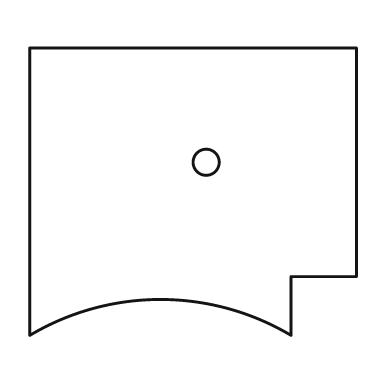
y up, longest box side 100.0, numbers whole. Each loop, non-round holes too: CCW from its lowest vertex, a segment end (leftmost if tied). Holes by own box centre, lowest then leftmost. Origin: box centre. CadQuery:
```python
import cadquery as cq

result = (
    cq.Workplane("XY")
    .moveTo(-50.0, -44.0)
    .threePointArc((-10.0, -33.0), (30.0, -44.0))
    .lineTo(30.0, -26.0)
    .lineTo(50.0, -26.0)
    .lineTo(50.0, 44.0)
    .lineTo(-50.0, 44.0)
    .close()
    .moveTo(4.0, 9.0)
    .circle(4.0)
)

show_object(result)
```